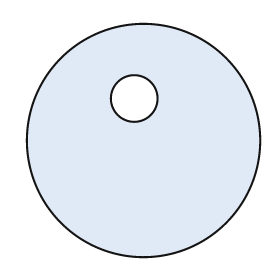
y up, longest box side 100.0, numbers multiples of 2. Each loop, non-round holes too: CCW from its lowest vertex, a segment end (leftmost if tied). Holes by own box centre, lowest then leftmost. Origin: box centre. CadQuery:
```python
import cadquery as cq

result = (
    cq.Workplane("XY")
    .moveTo(0.0, 0.0)
    .circle(50.0)
    .moveTo(-4.0, 18.0)
    .circle(10.0)
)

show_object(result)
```